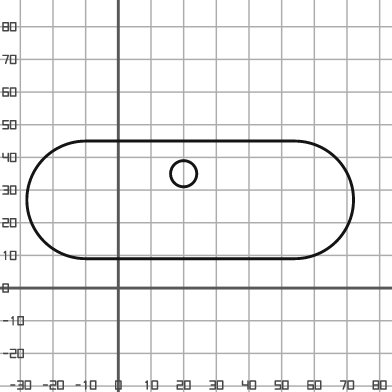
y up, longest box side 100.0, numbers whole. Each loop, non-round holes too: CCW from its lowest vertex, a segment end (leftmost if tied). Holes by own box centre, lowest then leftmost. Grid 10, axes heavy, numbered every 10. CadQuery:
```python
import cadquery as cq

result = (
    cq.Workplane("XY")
    .moveTo(-10.0, 9.0)
    .lineTo(54.0, 9.0)
    .threePointArc((72.0, 27.0), (54.0, 45.0))
    .lineTo(-10.0, 45.0)
    .threePointArc((-28.0, 27.0), (-10.0, 9.0))
    .close()
    .moveTo(20.0, 35.0)
    .circle(4.0)
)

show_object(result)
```